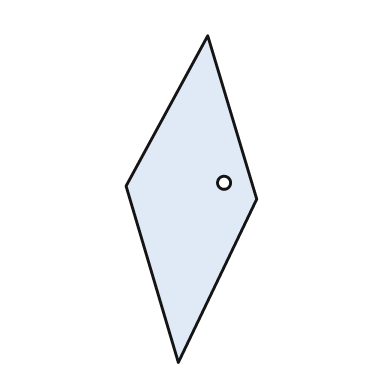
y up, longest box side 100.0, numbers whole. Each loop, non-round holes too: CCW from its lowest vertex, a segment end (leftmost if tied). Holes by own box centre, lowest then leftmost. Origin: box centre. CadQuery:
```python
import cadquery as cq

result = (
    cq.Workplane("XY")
    .moveTo(-4.0, -50.0)
    .lineTo(20.0, 0.0)
    .lineTo(5.0, 50.0)
    .lineTo(-20.0, 4.0)
    .close()
    .moveTo(10.0, 5.0)
    .circle(2.0)
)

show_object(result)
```